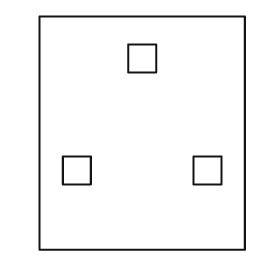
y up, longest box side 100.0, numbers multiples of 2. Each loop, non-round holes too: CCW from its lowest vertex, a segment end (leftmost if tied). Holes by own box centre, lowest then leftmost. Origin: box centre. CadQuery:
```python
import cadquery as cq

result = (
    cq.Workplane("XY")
    .moveTo(-44.0, -50.0)
    .lineTo(44.0, -50.0)
    .lineTo(44.0, 50.0)
    .lineTo(-44.0, 50.0)
    .close()
    .moveTo(-34.0, -22.0)
    .lineTo(-22.0, -22.0)
    .lineTo(-22.0, -10.0)
    .lineTo(-34.0, -10.0)
    .close()
    .moveTo(22.0, -22.0)
    .lineTo(34.0, -22.0)
    .lineTo(34.0, -10.0)
    .lineTo(22.0, -10.0)
    .close()
    .moveTo(-6.0, 26.0)
    .lineTo(6.0, 26.0)
    .lineTo(6.0, 38.0)
    .lineTo(-6.0, 38.0)
    .close()
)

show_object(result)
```